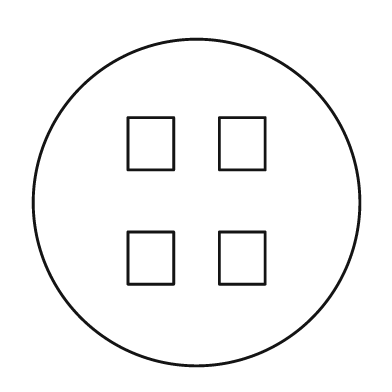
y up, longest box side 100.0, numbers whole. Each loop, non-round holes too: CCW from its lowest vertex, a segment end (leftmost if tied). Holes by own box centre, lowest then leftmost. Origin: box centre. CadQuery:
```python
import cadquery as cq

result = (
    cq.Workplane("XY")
    .moveTo(0.0, 0.0)
    .circle(50.0)
    .moveTo(-21.0, -25.0)
    .lineTo(-7.0, -25.0)
    .lineTo(-7.0, -9.0)
    .lineTo(-21.0, -9.0)
    .close()
    .moveTo(7.0, -25.0)
    .lineTo(21.0, -25.0)
    .lineTo(21.0, -9.0)
    .lineTo(7.0, -9.0)
    .close()
    .moveTo(-21.0, 10.0)
    .lineTo(-7.0, 10.0)
    .lineTo(-7.0, 26.0)
    .lineTo(-21.0, 26.0)
    .close()
    .moveTo(7.0, 10.0)
    .lineTo(21.0, 10.0)
    .lineTo(21.0, 26.0)
    .lineTo(7.0, 26.0)
    .close()
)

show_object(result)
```